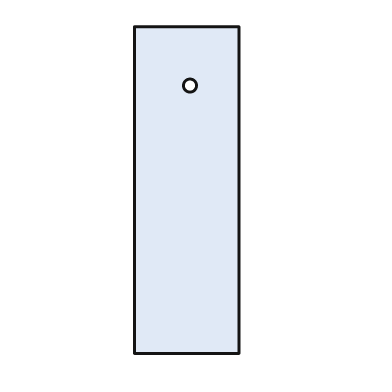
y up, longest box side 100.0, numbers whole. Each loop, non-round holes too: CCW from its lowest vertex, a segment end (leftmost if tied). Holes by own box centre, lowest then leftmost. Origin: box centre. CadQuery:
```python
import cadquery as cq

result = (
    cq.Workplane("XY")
    .moveTo(-16.0, -50.0)
    .lineTo(16.0, -50.0)
    .lineTo(16.0, 50.0)
    .lineTo(-16.0, 50.0)
    .close()
    .moveTo(1.0, 32.0)
    .circle(2.0)
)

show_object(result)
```